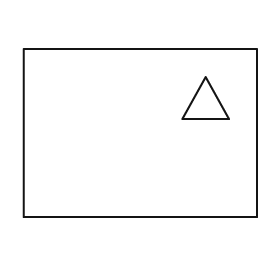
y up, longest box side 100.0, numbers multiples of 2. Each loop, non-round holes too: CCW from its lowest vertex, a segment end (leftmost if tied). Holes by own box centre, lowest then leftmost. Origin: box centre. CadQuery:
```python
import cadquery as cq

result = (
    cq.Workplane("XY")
    .moveTo(-50.0, -36.0)
    .lineTo(50.0, -36.0)
    .lineTo(50.0, 36.0)
    .lineTo(-50.0, 36.0)
    .close()
    .moveTo(18.0, 6.0)
    .lineTo(38.0, 6.0)
    .lineTo(28.0, 24.0)
    .close()
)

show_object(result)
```